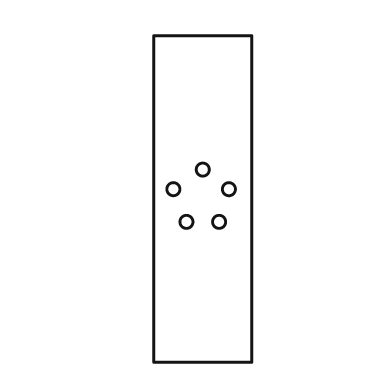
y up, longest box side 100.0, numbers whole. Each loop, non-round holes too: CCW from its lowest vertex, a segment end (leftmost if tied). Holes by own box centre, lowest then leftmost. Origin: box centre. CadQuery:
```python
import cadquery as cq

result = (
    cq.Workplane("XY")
    .moveTo(-15.0, -50.0)
    .lineTo(15.0, -50.0)
    .lineTo(15.0, 50.0)
    .lineTo(-15.0, 50.0)
    .close()
    .moveTo(-5.0, -7.0)
    .circle(2.0)
    .moveTo(5.0, -7.0)
    .circle(2.0)
    .moveTo(-9.0, 3.0)
    .circle(2.0)
    .moveTo(8.0, 3.0)
    .circle(2.0)
    .moveTo(0.0, 9.0)
    .circle(2.0)
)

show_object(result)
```